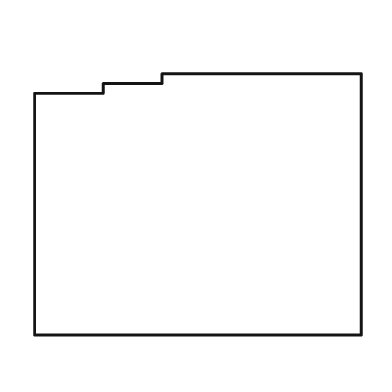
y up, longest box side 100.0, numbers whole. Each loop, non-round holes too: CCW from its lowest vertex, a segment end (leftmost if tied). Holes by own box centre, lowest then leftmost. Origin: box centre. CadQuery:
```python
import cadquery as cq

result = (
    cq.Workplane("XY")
    .moveTo(-50.0, -40.0)
    .lineTo(50.0, -40.0)
    .lineTo(50.0, 40.0)
    .lineTo(-11.0, 40.0)
    .lineTo(-11.0, 37.0)
    .lineTo(-29.0, 37.0)
    .lineTo(-29.0, 34.0)
    .lineTo(-50.0, 34.0)
    .close()
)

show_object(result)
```